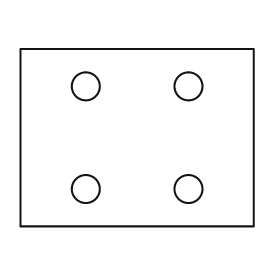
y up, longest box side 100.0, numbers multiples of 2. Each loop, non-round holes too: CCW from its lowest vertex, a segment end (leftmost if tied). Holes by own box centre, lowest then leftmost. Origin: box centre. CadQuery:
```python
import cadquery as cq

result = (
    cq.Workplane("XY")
    .moveTo(-50.0, -38.0)
    .lineTo(50.0, -38.0)
    .lineTo(50.0, 38.0)
    .lineTo(-50.0, 38.0)
    .close()
    .moveTo(-22.0, -22.0)
    .circle(6.0)
    .moveTo(22.0, -22.0)
    .circle(6.0)
    .moveTo(-22.0, 22.0)
    .circle(6.0)
    .moveTo(22.0, 22.0)
    .circle(6.0)
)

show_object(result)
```